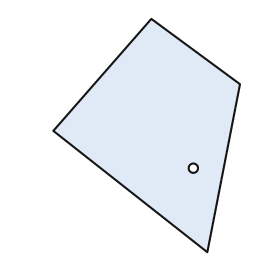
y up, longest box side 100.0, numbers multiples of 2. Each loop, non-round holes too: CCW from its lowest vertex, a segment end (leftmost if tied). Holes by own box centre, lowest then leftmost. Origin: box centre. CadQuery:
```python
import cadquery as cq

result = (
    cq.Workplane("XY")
    .moveTo(26.0, -50.0)
    .lineTo(40.0, 22.0)
    .lineTo(2.0, 50.0)
    .lineTo(-40.0, 2.0)
    .close()
    .moveTo(20.0, -14.0)
    .circle(2.0)
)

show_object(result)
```